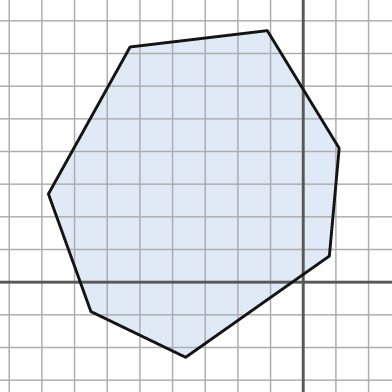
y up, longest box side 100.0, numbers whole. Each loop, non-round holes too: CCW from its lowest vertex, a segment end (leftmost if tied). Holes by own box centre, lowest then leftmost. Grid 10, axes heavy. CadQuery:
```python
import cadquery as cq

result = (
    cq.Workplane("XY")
    .moveTo(-36.0, -23.0)
    .lineTo(8.0, 8.0)
    .lineTo(11.0, 41.0)
    .lineTo(-11.0, 77.0)
    .lineTo(-53.0, 72.0)
    .lineTo(-78.0, 27.0)
    .lineTo(-65.0, -9.0)
    .close()
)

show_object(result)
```